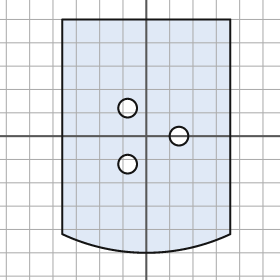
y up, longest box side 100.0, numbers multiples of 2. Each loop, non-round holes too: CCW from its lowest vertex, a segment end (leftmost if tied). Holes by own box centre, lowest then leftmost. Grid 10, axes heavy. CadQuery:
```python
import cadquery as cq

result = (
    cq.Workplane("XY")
    .moveTo(-36.0, -42.0)
    .threePointArc((0.0, -50.0), (36.0, -42.0))
    .lineTo(36.0, 50.0)
    .lineTo(-36.0, 50.0)
    .close()
    .moveTo(-8.0, -12.0)
    .circle(4.0)
    .moveTo(14.0, 0.0)
    .circle(4.0)
    .moveTo(-8.0, 12.0)
    .circle(4.0)
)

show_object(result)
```